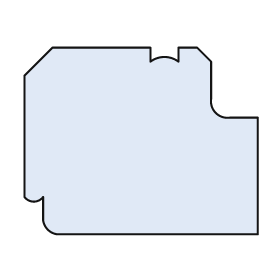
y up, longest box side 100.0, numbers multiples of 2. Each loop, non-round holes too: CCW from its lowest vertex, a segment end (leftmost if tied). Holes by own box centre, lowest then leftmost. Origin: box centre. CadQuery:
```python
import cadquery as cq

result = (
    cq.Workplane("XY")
    .moveTo(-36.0, -40.0)
    .lineTo(50.0, -40.0)
    .lineTo(50.0, 10.0)
    .lineTo(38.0, 10.0)
    .threePointArc((32.0, 12.0), (30.0, 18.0))
    .lineTo(30.0, 34.0)
    .lineTo(24.0, 40.0)
    .lineTo(16.0, 40.0)
    .lineTo(16.0, 34.0)
    .threePointArc((10.0, 36.0), (4.0, 34.0))
    .lineTo(4.0, 40.0)
    .lineTo(-38.0, 40.0)
    .lineTo(-50.0, 28.0)
    .lineTo(-50.0, -24.0)
    .threePointArc((-46.0, -26.0), (-42.0, -24.0))
    .lineTo(-42.0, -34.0)
    .threePointArc((-40.0, -38.0), (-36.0, -40.0))
    .close()
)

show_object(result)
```